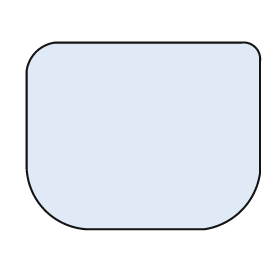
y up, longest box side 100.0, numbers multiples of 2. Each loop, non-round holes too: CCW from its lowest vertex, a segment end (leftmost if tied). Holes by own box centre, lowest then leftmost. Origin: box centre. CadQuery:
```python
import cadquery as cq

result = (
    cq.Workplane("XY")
    .moveTo(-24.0, -40.0)
    .lineTo(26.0, -40.0)
    .threePointArc((42.0, -32.0), (50.0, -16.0))
    .lineTo(50.0, 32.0)
    .threePointArc((48.0, 38.0), (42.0, 40.0))
    .lineTo(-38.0, 40.0)
    .threePointArc((-46.0, 36.0), (-50.0, 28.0))
    .lineTo(-50.0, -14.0)
    .threePointArc((-42.0, -32.0), (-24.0, -40.0))
    .close()
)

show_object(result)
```